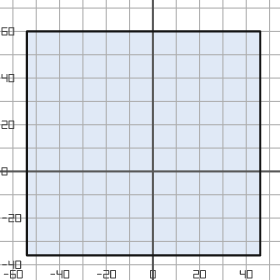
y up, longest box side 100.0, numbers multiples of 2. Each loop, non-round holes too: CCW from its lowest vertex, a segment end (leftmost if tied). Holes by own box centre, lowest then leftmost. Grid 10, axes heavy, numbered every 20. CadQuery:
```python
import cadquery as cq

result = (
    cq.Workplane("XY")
    .moveTo(-54.0, -36.0)
    .lineTo(46.0, -36.0)
    .lineTo(46.0, 60.0)
    .lineTo(-54.0, 60.0)
    .close()
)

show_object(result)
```